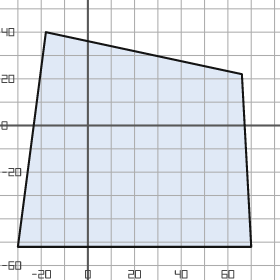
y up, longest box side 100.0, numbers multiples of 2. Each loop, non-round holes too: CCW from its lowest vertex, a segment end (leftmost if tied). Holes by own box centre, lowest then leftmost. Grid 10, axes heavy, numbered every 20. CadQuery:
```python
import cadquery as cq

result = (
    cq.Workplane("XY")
    .moveTo(-30.0, -52.0)
    .lineTo(70.0, -52.0)
    .lineTo(66.0, 22.0)
    .lineTo(-18.0, 40.0)
    .close()
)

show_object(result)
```